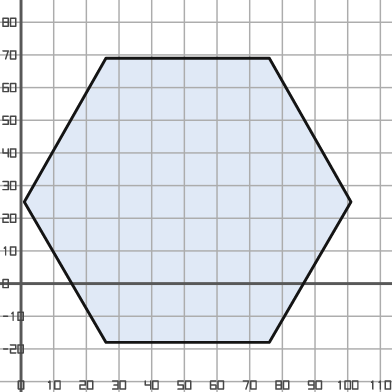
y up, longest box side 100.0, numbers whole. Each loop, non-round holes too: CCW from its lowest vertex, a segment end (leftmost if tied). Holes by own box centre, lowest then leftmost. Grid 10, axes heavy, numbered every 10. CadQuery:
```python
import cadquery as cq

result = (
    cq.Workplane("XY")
    .moveTo(26.0, -18.0)
    .lineTo(76.0, -18.0)
    .lineTo(101.0, 25.0)
    .lineTo(76.0, 69.0)
    .lineTo(26.0, 69.0)
    .lineTo(1.0, 25.0)
    .close()
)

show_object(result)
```